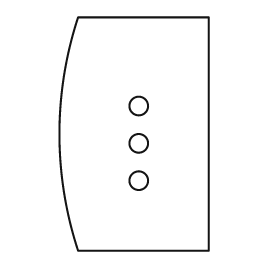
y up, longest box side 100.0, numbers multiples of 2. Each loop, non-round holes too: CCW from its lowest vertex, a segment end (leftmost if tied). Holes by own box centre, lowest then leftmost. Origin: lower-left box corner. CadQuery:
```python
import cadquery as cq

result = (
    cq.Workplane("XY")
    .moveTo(8.0, 0.0)
    .lineTo(64.0, 0.0)
    .lineTo(64.0, 100.0)
    .lineTo(8.0, 100.0)
    .threePointArc((0.0, 50.0), (8.0, 0.0))
    .close()
    .moveTo(34.0, 30.0)
    .circle(4.0)
    .moveTo(34.0, 46.0)
    .circle(4.0)
    .moveTo(34.0, 62.0)
    .circle(4.0)
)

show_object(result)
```